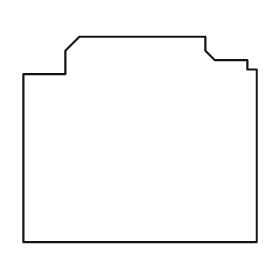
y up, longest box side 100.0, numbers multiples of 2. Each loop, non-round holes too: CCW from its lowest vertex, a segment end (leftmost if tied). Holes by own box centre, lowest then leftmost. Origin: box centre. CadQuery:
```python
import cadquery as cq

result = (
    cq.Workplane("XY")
    .moveTo(-50.0, -44.0)
    .lineTo(50.0, -44.0)
    .lineTo(50.0, 30.0)
    .lineTo(46.0, 30.0)
    .lineTo(46.0, 34.0)
    .lineTo(32.0, 34.0)
    .lineTo(28.0, 38.0)
    .lineTo(28.0, 44.0)
    .lineTo(-26.0, 44.0)
    .lineTo(-32.0, 38.0)
    .lineTo(-32.0, 28.0)
    .lineTo(-50.0, 28.0)
    .close()
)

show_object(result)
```